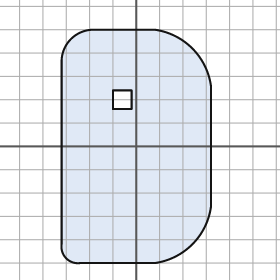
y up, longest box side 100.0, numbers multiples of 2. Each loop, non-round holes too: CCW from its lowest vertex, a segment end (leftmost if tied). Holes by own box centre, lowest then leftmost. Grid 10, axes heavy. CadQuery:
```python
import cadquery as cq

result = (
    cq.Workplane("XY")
    .moveTo(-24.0, -50.0)
    .lineTo(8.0, -50.0)
    .threePointArc((24.0, -42.0), (32.0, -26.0))
    .lineTo(32.0, 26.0)
    .threePointArc((24.0, 42.0), (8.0, 50.0))
    .lineTo(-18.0, 50.0)
    .threePointArc((-28.0, 46.0), (-32.0, 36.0))
    .lineTo(-32.0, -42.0)
    .threePointArc((-30.0, -48.0), (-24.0, -50.0))
    .close()
    .moveTo(-10.0, 16.0)
    .lineTo(-2.0, 16.0)
    .lineTo(-2.0, 24.0)
    .lineTo(-10.0, 24.0)
    .close()
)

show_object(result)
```